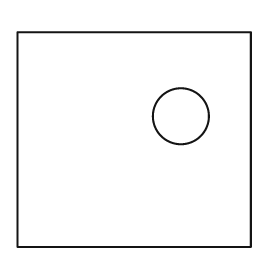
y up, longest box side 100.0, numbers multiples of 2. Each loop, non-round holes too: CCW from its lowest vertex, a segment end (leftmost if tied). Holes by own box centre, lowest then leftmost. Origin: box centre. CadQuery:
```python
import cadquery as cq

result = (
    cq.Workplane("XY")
    .moveTo(-50.0, -46.0)
    .lineTo(50.0, -46.0)
    .lineTo(50.0, 46.0)
    .lineTo(-50.0, 46.0)
    .close()
    .moveTo(20.0, 10.0)
    .circle(12.0)
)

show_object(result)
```